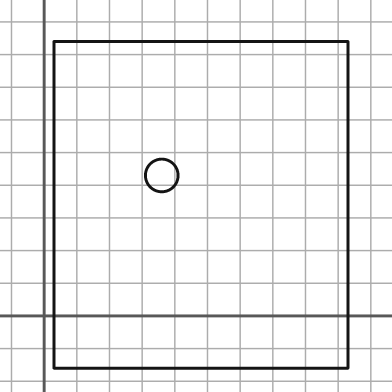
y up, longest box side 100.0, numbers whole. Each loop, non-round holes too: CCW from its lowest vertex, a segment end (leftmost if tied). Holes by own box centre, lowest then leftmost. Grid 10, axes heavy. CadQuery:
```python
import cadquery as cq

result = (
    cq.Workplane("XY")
    .moveTo(3.0, -16.0)
    .lineTo(93.0, -16.0)
    .lineTo(93.0, 84.0)
    .lineTo(3.0, 84.0)
    .close()
    .moveTo(36.0, 43.0)
    .circle(5.0)
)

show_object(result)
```